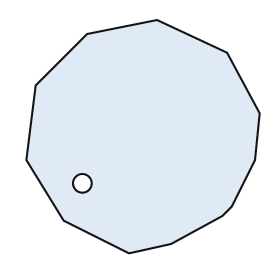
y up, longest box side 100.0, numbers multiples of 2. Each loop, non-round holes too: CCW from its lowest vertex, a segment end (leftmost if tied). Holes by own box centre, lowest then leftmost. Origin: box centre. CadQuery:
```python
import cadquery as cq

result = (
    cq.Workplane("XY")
    .moveTo(-6.0, -50.0)
    .lineTo(12.0, -46.0)
    .lineTo(34.0, -34.0)
    .lineTo(38.0, -30.0)
    .lineTo(48.0, -10.0)
    .lineTo(50.0, 10.0)
    .lineTo(36.0, 36.0)
    .lineTo(6.0, 50.0)
    .lineTo(-24.0, 44.0)
    .lineTo(-46.0, 22.0)
    .lineTo(-50.0, -10.0)
    .lineTo(-34.0, -36.0)
    .close()
    .moveTo(-26.0, -20.0)
    .circle(4.0)
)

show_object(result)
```